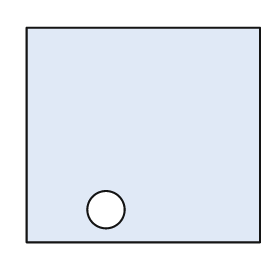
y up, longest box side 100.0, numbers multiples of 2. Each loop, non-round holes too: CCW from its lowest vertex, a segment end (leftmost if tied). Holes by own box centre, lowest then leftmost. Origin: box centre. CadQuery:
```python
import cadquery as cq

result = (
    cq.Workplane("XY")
    .moveTo(-50.0, -46.0)
    .lineTo(50.0, -46.0)
    .lineTo(50.0, 46.0)
    .lineTo(-50.0, 46.0)
    .close()
    .moveTo(-16.0, -32.0)
    .circle(8.0)
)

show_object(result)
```